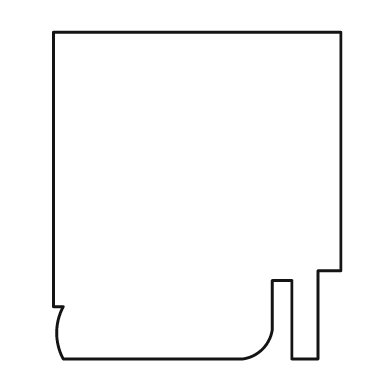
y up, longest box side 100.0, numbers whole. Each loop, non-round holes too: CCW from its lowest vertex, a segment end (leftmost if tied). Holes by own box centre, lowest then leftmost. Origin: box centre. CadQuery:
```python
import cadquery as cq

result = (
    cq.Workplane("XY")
    .moveTo(-41.0, -50.0)
    .lineTo(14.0, -50.0)
    .threePointArc((20.0, -47.0), (23.0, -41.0))
    .lineTo(23.0, -26.0)
    .lineTo(29.0, -26.0)
    .lineTo(29.0, -50.0)
    .lineTo(37.0, -50.0)
    .lineTo(37.0, -23.0)
    .lineTo(44.0, -23.0)
    .lineTo(44.0, 50.0)
    .lineTo(-44.0, 50.0)
    .lineTo(-44.0, -34.0)
    .lineTo(-41.0, -34.0)
    .threePointArc((-43.0, -42.0), (-41.0, -50.0))
    .close()
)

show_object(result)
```